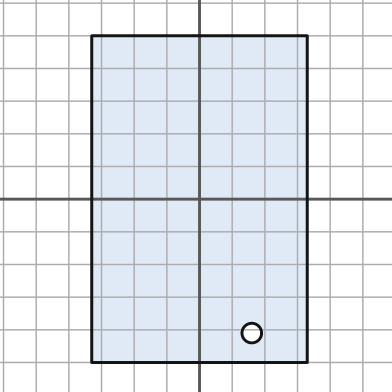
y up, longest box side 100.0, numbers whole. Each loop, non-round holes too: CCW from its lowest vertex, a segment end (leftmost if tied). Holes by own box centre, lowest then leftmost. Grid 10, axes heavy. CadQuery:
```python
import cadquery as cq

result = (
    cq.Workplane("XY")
    .moveTo(-33.0, -50.0)
    .lineTo(33.0, -50.0)
    .lineTo(33.0, 50.0)
    .lineTo(-33.0, 50.0)
    .close()
    .moveTo(16.0, -41.0)
    .circle(3.0)
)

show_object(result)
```